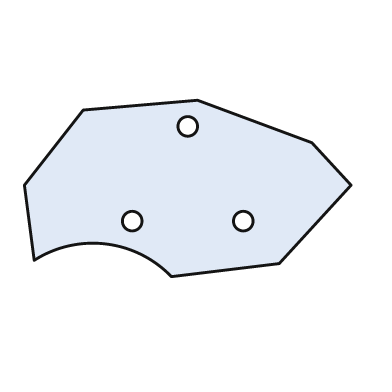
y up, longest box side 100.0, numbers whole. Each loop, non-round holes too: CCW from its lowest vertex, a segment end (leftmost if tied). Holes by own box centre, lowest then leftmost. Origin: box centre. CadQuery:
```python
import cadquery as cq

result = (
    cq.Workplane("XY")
    .moveTo(-5.0, -27.0)
    .lineTo(28.0, -23.0)
    .lineTo(50.0, 1.0)
    .lineTo(38.0, 14.0)
    .lineTo(3.0, 27.0)
    .lineTo(-32.0, 24.0)
    .lineTo(-50.0, 1.0)
    .lineTo(-47.0, -22.0)
    .threePointArc((-25.0, -17.0), (-5.0, -27.0))
    .close()
    .moveTo(-17.0, -10.0)
    .circle(3.0)
    .moveTo(17.0, -10.0)
    .circle(3.0)
    .moveTo(0.0, 19.0)
    .circle(3.0)
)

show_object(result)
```